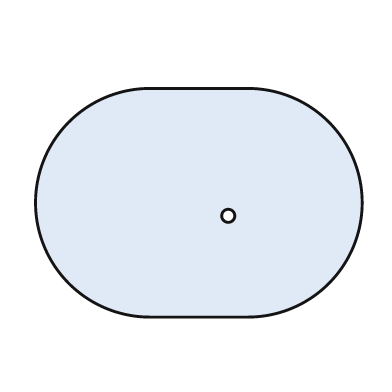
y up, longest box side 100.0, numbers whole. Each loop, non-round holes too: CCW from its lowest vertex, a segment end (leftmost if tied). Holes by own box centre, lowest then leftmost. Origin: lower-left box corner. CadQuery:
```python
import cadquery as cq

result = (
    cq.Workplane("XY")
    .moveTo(35.0, 0.0)
    .lineTo(65.0, 0.0)
    .threePointArc((100.0, 35.0), (65.0, 70.0))
    .lineTo(35.0, 70.0)
    .threePointArc((0.0, 35.0), (35.0, 0.0))
    .close()
    .moveTo(59.0, 31.0)
    .circle(2.0)
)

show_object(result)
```